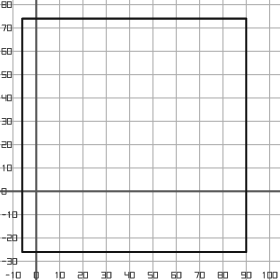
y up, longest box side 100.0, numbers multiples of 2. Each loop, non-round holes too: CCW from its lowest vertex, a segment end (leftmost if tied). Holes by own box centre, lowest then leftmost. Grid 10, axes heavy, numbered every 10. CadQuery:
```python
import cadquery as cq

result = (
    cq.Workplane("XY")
    .moveTo(-6.0, -26.0)
    .lineTo(90.0, -26.0)
    .lineTo(90.0, 74.0)
    .lineTo(-6.0, 74.0)
    .close()
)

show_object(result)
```